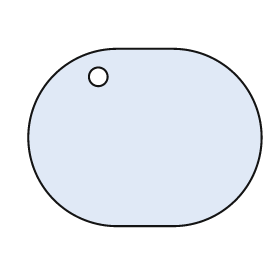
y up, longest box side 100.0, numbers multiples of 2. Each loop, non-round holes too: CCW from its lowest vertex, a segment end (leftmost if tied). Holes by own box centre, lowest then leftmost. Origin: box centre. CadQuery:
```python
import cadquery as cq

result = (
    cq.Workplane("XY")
    .moveTo(-12.0, -38.0)
    .lineTo(12.0, -38.0)
    .threePointArc((50.0, 0.0), (12.0, 38.0))
    .lineTo(-12.0, 38.0)
    .threePointArc((-50.0, 0.0), (-12.0, -38.0))
    .close()
    .moveTo(-20.0, 26.0)
    .circle(4.0)
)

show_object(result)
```